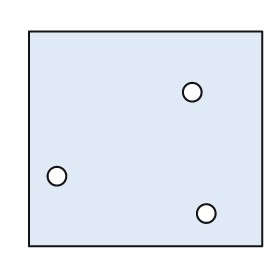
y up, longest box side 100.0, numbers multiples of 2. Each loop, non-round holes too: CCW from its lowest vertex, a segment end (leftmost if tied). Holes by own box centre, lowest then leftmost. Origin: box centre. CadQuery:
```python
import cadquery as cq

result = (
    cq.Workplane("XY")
    .moveTo(-50.0, -46.0)
    .lineTo(50.0, -46.0)
    .lineTo(50.0, 46.0)
    .lineTo(-50.0, 46.0)
    .close()
    .moveTo(26.0, -32.0)
    .circle(4.0)
    .moveTo(-38.0, -16.0)
    .circle(4.0)
    .moveTo(20.0, 20.0)
    .circle(4.0)
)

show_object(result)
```